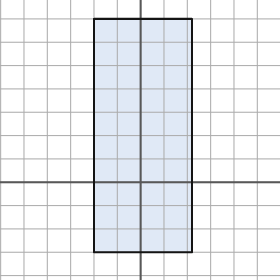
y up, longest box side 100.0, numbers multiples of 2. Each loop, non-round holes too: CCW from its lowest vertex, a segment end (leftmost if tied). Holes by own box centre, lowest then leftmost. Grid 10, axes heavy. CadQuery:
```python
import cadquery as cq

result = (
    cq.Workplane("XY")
    .moveTo(-20.0, -30.0)
    .lineTo(22.0, -30.0)
    .lineTo(22.0, 70.0)
    .lineTo(-20.0, 70.0)
    .close()
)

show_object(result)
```